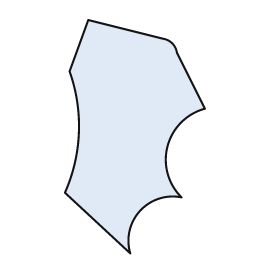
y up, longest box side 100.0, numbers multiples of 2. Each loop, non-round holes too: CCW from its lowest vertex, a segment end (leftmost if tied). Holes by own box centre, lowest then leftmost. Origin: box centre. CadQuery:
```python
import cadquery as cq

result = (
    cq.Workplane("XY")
    .moveTo(-2.0, -50.0)
    .threePointArc((2.0, -32.0), (20.0, -26.0))
    .threePointArc((14.0, -4.0), (30.0, 12.0))
    .lineTo(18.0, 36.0)
    .threePointArc((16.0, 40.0), (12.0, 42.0))
    .lineTo(-20.0, 50.0)
    .lineTo(-28.0, 28.0)
    .threePointArc((-24.0, 2.0), (-30.0, -24.0))
    .close()
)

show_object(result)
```